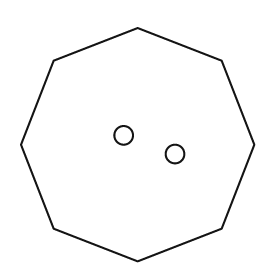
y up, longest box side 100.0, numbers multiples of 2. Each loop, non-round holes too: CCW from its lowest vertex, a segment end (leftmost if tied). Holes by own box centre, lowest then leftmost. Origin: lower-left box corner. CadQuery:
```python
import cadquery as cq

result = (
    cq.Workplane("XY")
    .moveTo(50.0, 0.0)
    .lineTo(86.0, 14.0)
    .lineTo(100.0, 50.0)
    .lineTo(86.0, 86.0)
    .lineTo(50.0, 100.0)
    .lineTo(14.0, 86.0)
    .lineTo(0.0, 50.0)
    .lineTo(14.0, 14.0)
    .close()
    .moveTo(66.0, 46.0)
    .circle(4.0)
    .moveTo(44.0, 54.0)
    .circle(4.0)
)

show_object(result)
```